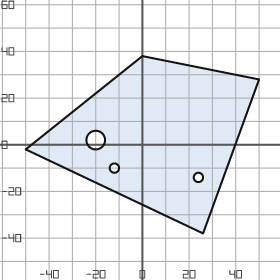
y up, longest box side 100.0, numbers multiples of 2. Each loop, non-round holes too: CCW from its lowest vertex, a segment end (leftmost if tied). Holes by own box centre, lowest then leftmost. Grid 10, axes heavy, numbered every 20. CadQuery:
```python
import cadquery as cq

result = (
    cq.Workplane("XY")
    .moveTo(26.0, -38.0)
    .lineTo(50.0, 28.0)
    .lineTo(0.0, 38.0)
    .lineTo(-50.0, -2.0)
    .close()
    .moveTo(24.0, -14.0)
    .circle(2.0)
    .moveTo(-12.0, -10.0)
    .circle(2.0)
    .moveTo(-20.0, 2.0)
    .circle(4.0)
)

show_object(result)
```